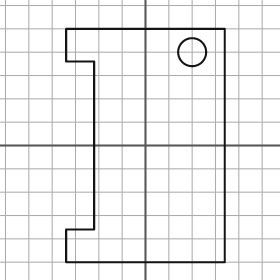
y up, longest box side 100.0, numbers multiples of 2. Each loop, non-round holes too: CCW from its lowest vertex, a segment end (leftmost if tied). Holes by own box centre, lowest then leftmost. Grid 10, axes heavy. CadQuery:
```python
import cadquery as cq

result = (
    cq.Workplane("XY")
    .moveTo(-34.0, -50.0)
    .lineTo(34.0, -50.0)
    .lineTo(34.0, 50.0)
    .lineTo(-34.0, 50.0)
    .lineTo(-34.0, 36.0)
    .lineTo(-22.0, 36.0)
    .lineTo(-22.0, -36.0)
    .lineTo(-34.0, -36.0)
    .close()
    .moveTo(20.0, 40.0)
    .circle(6.0)
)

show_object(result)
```